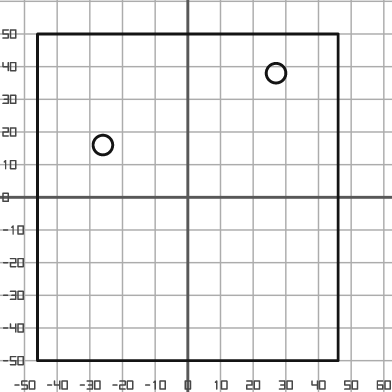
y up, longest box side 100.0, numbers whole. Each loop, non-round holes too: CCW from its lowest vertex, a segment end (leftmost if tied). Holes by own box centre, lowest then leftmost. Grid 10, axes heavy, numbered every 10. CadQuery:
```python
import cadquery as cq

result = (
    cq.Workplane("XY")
    .moveTo(-46.0, -50.0)
    .lineTo(46.0, -50.0)
    .lineTo(46.0, 50.0)
    .lineTo(-46.0, 50.0)
    .close()
    .moveTo(-26.0, 16.0)
    .circle(3.0)
    .moveTo(27.0, 38.0)
    .circle(3.0)
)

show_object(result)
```